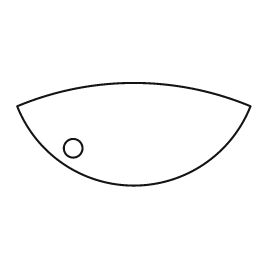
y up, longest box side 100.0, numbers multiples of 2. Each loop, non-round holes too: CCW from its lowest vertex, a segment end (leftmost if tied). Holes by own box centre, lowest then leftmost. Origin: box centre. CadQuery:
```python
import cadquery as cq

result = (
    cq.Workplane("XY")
    .moveTo(-50.0, 12.0)
    .threePointArc((0.0, -22.0), (50.0, 12.0))
    .threePointArc((0.0, 22.0), (-50.0, 12.0))
    .close()
    .moveTo(-26.0, -6.0)
    .circle(4.0)
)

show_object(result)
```